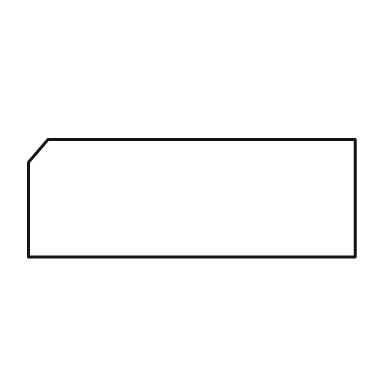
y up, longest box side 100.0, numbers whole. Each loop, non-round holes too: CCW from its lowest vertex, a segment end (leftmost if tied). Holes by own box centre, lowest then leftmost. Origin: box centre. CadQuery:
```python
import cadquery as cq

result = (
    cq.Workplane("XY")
    .moveTo(-50.0, -18.0)
    .lineTo(50.0, -18.0)
    .lineTo(50.0, 18.0)
    .lineTo(-44.0, 18.0)
    .lineTo(-50.0, 11.0)
    .close()
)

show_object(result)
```